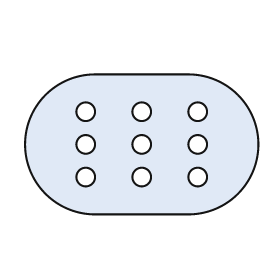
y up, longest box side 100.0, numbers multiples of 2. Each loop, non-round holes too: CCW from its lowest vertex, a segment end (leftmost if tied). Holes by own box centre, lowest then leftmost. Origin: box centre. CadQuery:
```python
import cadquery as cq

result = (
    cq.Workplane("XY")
    .moveTo(-20.0, -30.0)
    .lineTo(20.0, -30.0)
    .threePointArc((50.0, 0.0), (20.0, 30.0))
    .lineTo(-20.0, 30.0)
    .threePointArc((-50.0, 0.0), (-20.0, -30.0))
    .close()
    .moveTo(-24.0, -14.0)
    .circle(4.0)
    .moveTo(0.0, -14.0)
    .circle(4.0)
    .moveTo(24.0, -14.0)
    .circle(4.0)
    .moveTo(-24.0, 0.0)
    .circle(4.0)
    .moveTo(0.0, 0.0)
    .circle(4.0)
    .moveTo(24.0, 0.0)
    .circle(4.0)
    .moveTo(-24.0, 14.0)
    .circle(4.0)
    .moveTo(0.0, 14.0)
    .circle(4.0)
    .moveTo(24.0, 14.0)
    .circle(4.0)
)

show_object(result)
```